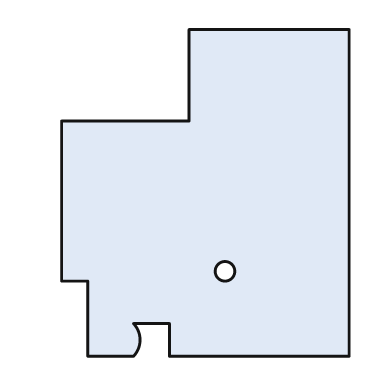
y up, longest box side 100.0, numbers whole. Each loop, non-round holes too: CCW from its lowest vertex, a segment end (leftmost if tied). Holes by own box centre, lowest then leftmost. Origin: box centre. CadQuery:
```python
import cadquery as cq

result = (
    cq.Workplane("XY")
    .moveTo(-36.0, -50.0)
    .lineTo(-22.0, -50.0)
    .threePointArc((-20.0, -45.0), (-22.0, -40.0))
    .lineTo(-11.0, -40.0)
    .lineTo(-11.0, -50.0)
    .lineTo(44.0, -50.0)
    .lineTo(44.0, 50.0)
    .lineTo(-5.0, 50.0)
    .lineTo(-5.0, 22.0)
    .lineTo(-44.0, 22.0)
    .lineTo(-44.0, -27.0)
    .lineTo(-36.0, -27.0)
    .close()
    .moveTo(6.0, -24.0)
    .circle(3.0)
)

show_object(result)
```